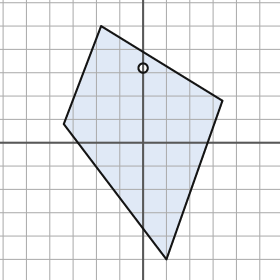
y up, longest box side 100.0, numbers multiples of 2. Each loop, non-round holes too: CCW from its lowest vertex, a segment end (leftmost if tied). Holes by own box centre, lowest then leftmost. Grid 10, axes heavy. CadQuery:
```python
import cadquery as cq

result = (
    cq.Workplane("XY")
    .moveTo(10.0, -50.0)
    .lineTo(34.0, 18.0)
    .lineTo(-18.0, 50.0)
    .lineTo(-34.0, 8.0)
    .close()
    .moveTo(0.0, 32.0)
    .circle(2.0)
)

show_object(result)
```